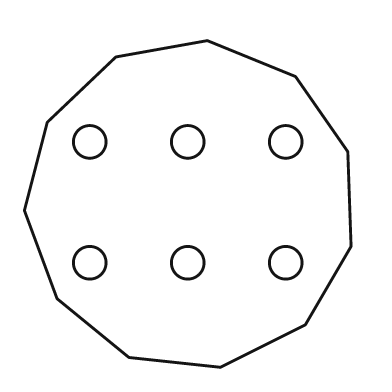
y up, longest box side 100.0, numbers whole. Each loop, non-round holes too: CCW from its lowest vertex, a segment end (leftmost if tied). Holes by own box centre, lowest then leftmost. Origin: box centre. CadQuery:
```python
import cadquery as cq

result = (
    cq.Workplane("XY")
    .moveTo(10.0, -50.0)
    .lineTo(36.0, -37.0)
    .lineTo(50.0, -13.0)
    .lineTo(49.0, 16.0)
    .lineTo(33.0, 39.0)
    .lineTo(6.0, 50.0)
    .lineTo(-22.0, 45.0)
    .lineTo(-43.0, 25.0)
    .lineTo(-50.0, -2.0)
    .lineTo(-40.0, -29.0)
    .lineTo(-18.0, -47.0)
    .close()
    .moveTo(-30.0, -18.0)
    .circle(5.0)
    .moveTo(0.0, -18.0)
    .circle(5.0)
    .moveTo(30.0, -18.0)
    .circle(5.0)
    .moveTo(-30.0, 19.0)
    .circle(5.0)
    .moveTo(0.0, 19.0)
    .circle(5.0)
    .moveTo(30.0, 19.0)
    .circle(5.0)
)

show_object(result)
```